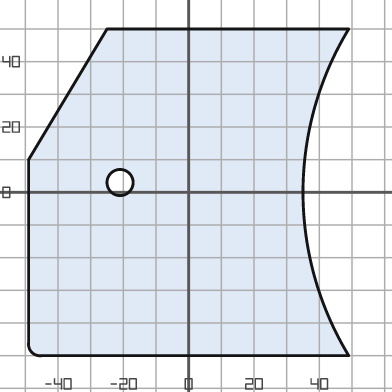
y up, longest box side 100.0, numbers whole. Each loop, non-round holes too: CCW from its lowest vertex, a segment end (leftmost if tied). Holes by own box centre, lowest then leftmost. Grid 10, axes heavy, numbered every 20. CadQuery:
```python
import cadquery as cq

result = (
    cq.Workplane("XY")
    .moveTo(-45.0, -50.0)
    .lineTo(49.0, -50.0)
    .threePointArc((35.0, 0.0), (49.0, 50.0))
    .lineTo(-25.0, 50.0)
    .lineTo(-49.0, 10.0)
    .lineTo(-49.0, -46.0)
    .threePointArc((-48.0, -49.0), (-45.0, -50.0))
    .close()
    .moveTo(-21.0, 3.0)
    .circle(4.0)
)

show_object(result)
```